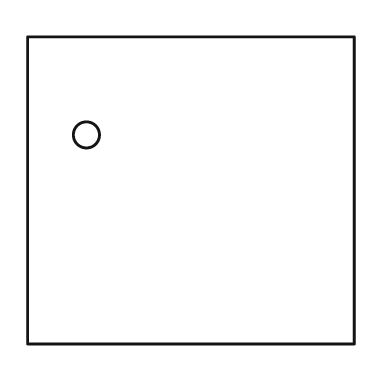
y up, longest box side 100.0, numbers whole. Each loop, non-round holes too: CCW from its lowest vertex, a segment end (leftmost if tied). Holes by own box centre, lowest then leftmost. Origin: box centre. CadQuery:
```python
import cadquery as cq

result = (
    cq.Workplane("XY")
    .moveTo(-50.0, -47.0)
    .lineTo(50.0, -47.0)
    .lineTo(50.0, 47.0)
    .lineTo(-50.0, 47.0)
    .close()
    .moveTo(-32.0, 17.0)
    .circle(4.0)
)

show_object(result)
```